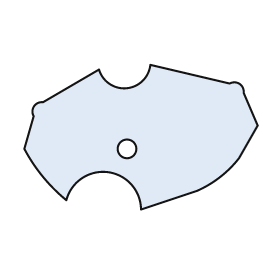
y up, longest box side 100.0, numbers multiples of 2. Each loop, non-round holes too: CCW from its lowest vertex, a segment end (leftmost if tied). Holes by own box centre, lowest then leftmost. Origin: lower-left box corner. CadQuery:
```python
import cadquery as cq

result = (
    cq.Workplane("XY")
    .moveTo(50.0, 0.0)
    .lineTo(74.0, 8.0)
    .threePointArc((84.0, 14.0), (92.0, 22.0))
    .lineTo(100.0, 36.0)
    .lineTo(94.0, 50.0)
    .threePointArc((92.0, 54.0), (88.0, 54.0))
    .lineTo(54.0, 62.0)
    .threePointArc((44.0, 52.0), (32.0, 60.0))
    .lineTo(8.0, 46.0)
    .threePointArc((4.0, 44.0), (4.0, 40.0))
    .lineTo(0.0, 26.0)
    .threePointArc((8.0, 14.0), (18.0, 4.0))
    .threePointArc((36.0, 16.0), (50.0, 0.0))
    .close()
    .moveTo(44.0, 26.0)
    .circle(4.0)
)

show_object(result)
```